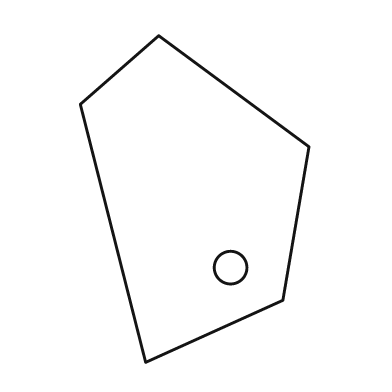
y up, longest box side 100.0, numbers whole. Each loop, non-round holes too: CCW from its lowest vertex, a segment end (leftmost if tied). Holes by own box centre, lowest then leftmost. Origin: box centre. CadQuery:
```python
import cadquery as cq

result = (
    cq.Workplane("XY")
    .moveTo(-15.0, -50.0)
    .lineTo(27.0, -31.0)
    .lineTo(35.0, 16.0)
    .lineTo(-11.0, 50.0)
    .lineTo(-35.0, 29.0)
    .close()
    .moveTo(11.0, -21.0)
    .circle(5.0)
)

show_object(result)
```